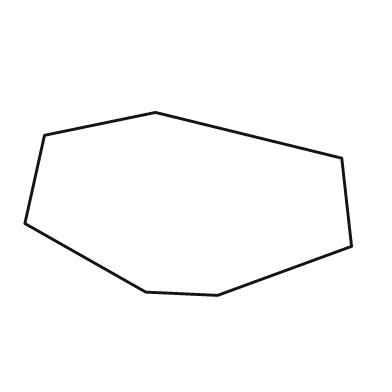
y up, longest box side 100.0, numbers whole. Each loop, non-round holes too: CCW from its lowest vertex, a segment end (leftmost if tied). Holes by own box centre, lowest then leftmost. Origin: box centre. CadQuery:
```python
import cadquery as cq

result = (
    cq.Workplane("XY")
    .moveTo(9.0, -28.0)
    .lineTo(50.0, -13.0)
    .lineTo(47.0, 14.0)
    .lineTo(-10.0, 28.0)
    .lineTo(-44.0, 21.0)
    .lineTo(-50.0, -6.0)
    .lineTo(-13.0, -27.0)
    .close()
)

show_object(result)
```